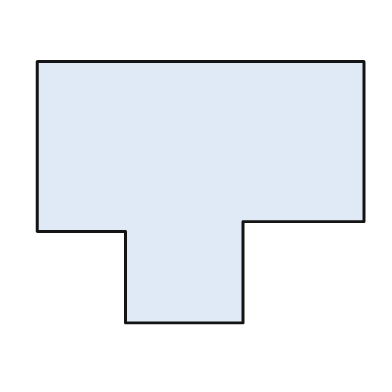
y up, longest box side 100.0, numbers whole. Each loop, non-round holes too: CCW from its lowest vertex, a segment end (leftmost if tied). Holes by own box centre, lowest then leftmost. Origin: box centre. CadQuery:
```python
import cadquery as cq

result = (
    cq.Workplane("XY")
    .moveTo(-23.0, -40.0)
    .lineTo(13.0, -40.0)
    .lineTo(13.0, -9.0)
    .lineTo(50.0, -9.0)
    .lineTo(50.0, 40.0)
    .lineTo(-50.0, 40.0)
    .lineTo(-50.0, -12.0)
    .lineTo(-23.0, -12.0)
    .close()
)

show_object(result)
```